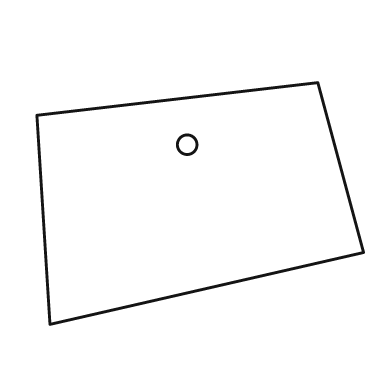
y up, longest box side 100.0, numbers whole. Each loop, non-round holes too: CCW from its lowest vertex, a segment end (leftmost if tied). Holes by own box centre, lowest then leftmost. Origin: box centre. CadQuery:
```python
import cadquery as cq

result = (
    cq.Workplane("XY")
    .moveTo(-46.0, -37.0)
    .lineTo(50.0, -15.0)
    .lineTo(36.0, 37.0)
    .lineTo(-50.0, 27.0)
    .close()
    .moveTo(-4.0, 18.0)
    .circle(3.0)
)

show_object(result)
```